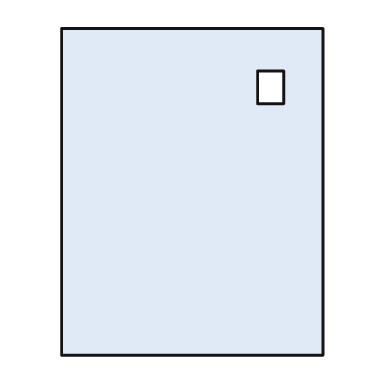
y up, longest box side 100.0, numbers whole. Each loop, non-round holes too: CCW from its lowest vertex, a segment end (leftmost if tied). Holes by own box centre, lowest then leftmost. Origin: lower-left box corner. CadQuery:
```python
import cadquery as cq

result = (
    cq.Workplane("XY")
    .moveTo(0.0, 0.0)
    .lineTo(80.0, 0.0)
    .lineTo(80.0, 100.0)
    .lineTo(0.0, 100.0)
    .close()
    .moveTo(60.0, 77.0)
    .lineTo(68.0, 77.0)
    .lineTo(68.0, 87.0)
    .lineTo(60.0, 87.0)
    .close()
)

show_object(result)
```